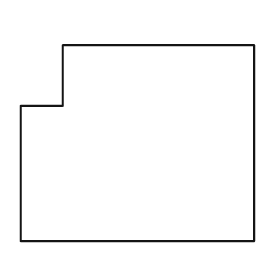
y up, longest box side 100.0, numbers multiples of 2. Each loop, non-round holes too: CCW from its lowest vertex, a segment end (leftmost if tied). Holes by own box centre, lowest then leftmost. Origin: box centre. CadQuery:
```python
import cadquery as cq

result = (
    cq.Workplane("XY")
    .moveTo(-50.0, -42.0)
    .lineTo(50.0, -42.0)
    .lineTo(50.0, 42.0)
    .lineTo(-32.0, 42.0)
    .lineTo(-32.0, 16.0)
    .lineTo(-50.0, 16.0)
    .close()
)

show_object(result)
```